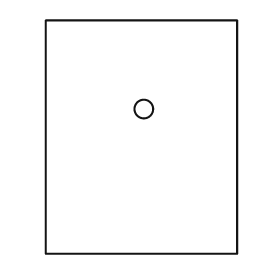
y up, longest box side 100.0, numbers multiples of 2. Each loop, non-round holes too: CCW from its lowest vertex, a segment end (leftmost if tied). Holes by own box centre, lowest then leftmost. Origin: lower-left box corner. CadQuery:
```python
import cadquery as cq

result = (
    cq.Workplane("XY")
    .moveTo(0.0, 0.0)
    .lineTo(82.0, 0.0)
    .lineTo(82.0, 100.0)
    .lineTo(0.0, 100.0)
    .close()
    .moveTo(42.0, 62.0)
    .circle(4.0)
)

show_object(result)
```